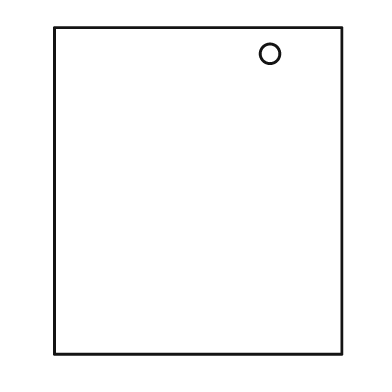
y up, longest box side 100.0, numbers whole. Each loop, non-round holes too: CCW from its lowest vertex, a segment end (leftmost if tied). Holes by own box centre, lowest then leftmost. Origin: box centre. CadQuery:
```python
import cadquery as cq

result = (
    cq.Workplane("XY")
    .moveTo(-44.0, -50.0)
    .lineTo(44.0, -50.0)
    .lineTo(44.0, 50.0)
    .lineTo(-44.0, 50.0)
    .close()
    .moveTo(22.0, 42.0)
    .circle(3.0)
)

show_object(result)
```